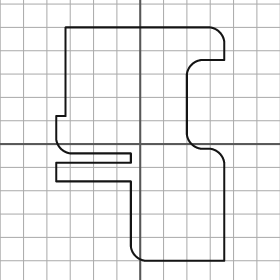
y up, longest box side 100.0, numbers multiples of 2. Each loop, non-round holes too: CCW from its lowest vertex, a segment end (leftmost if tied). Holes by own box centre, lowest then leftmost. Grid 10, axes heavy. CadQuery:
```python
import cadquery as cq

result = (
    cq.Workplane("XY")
    .moveTo(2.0, -50.0)
    .lineTo(36.0, -50.0)
    .lineTo(36.0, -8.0)
    .threePointArc((34.0, -4.0), (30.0, -2.0))
    .lineTo(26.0, -2.0)
    .threePointArc((22.0, 0.0), (20.0, 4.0))
    .lineTo(20.0, 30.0)
    .threePointArc((22.0, 34.0), (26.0, 36.0))
    .lineTo(36.0, 36.0)
    .lineTo(36.0, 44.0)
    .threePointArc((34.0, 48.0), (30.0, 50.0))
    .lineTo(-32.0, 50.0)
    .lineTo(-32.0, 12.0)
    .lineTo(-36.0, 12.0)
    .lineTo(-36.0, 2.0)
    .threePointArc((-34.0, -2.0), (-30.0, -4.0))
    .lineTo(-4.0, -4.0)
    .lineTo(-4.0, -8.0)
    .lineTo(-36.0, -8.0)
    .lineTo(-36.0, -16.0)
    .lineTo(-4.0, -16.0)
    .lineTo(-4.0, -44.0)
    .threePointArc((-2.0, -48.0), (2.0, -50.0))
    .close()
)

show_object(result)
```